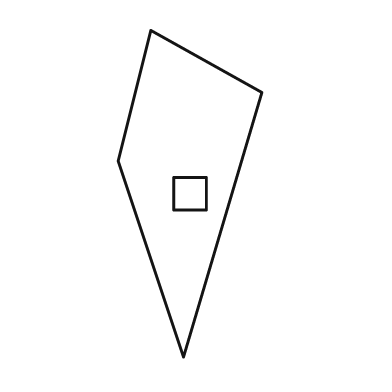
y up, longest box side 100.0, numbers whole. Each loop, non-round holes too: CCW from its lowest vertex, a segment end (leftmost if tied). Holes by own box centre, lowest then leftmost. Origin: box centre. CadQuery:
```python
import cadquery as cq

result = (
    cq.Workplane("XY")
    .moveTo(-2.0, -50.0)
    .lineTo(22.0, 31.0)
    .lineTo(-12.0, 50.0)
    .lineTo(-22.0, 10.0)
    .close()
    .moveTo(-5.0, -5.0)
    .lineTo(5.0, -5.0)
    .lineTo(5.0, 5.0)
    .lineTo(-5.0, 5.0)
    .close()
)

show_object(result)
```